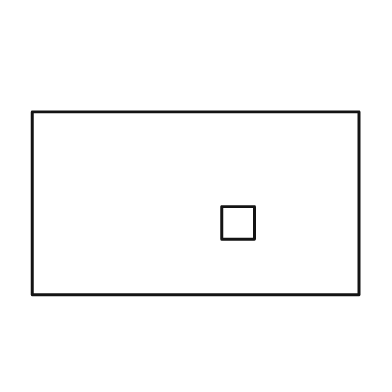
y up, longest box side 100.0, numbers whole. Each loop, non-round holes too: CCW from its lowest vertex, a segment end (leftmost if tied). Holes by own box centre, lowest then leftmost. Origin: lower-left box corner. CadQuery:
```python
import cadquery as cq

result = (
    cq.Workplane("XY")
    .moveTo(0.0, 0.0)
    .lineTo(100.0, 0.0)
    .lineTo(100.0, 56.0)
    .lineTo(0.0, 56.0)
    .close()
    .moveTo(58.0, 17.0)
    .lineTo(68.0, 17.0)
    .lineTo(68.0, 27.0)
    .lineTo(58.0, 27.0)
    .close()
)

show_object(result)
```